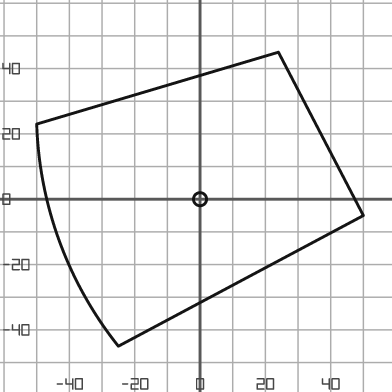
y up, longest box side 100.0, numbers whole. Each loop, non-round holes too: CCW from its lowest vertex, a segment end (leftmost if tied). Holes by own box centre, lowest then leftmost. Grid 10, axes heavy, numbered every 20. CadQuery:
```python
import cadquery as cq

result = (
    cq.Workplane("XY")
    .moveTo(-25.0, -45.0)
    .lineTo(50.0, -5.0)
    .lineTo(24.0, 45.0)
    .lineTo(-50.0, 23.0)
    .threePointArc((-43.0, -13.0), (-25.0, -45.0))
    .close()
    .moveTo(0.0, 0.0)
    .circle(2.0)
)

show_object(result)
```